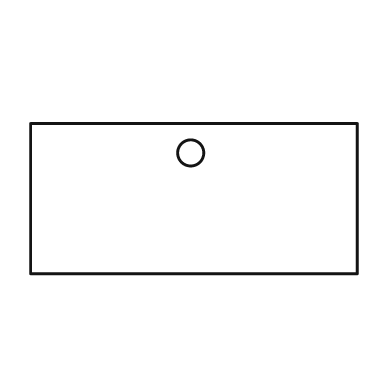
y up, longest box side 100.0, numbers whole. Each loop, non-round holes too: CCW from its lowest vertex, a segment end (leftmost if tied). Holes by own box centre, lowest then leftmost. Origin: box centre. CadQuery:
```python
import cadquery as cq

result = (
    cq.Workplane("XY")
    .moveTo(-50.0, -23.0)
    .lineTo(50.0, -23.0)
    .lineTo(50.0, 23.0)
    .lineTo(-50.0, 23.0)
    .close()
    .moveTo(-1.0, 14.0)
    .circle(4.0)
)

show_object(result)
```